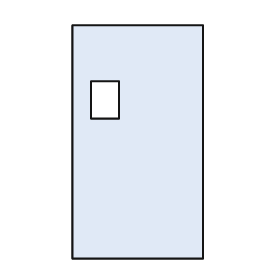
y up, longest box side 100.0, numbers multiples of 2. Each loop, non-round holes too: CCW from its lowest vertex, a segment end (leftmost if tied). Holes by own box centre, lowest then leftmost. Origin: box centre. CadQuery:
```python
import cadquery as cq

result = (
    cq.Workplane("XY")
    .moveTo(-28.0, -50.0)
    .lineTo(28.0, -50.0)
    .lineTo(28.0, 50.0)
    .lineTo(-28.0, 50.0)
    .close()
    .moveTo(-20.0, 10.0)
    .lineTo(-8.0, 10.0)
    .lineTo(-8.0, 26.0)
    .lineTo(-20.0, 26.0)
    .close()
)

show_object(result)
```